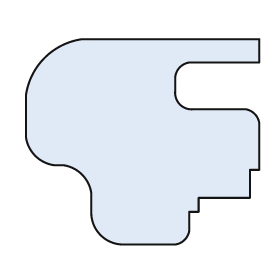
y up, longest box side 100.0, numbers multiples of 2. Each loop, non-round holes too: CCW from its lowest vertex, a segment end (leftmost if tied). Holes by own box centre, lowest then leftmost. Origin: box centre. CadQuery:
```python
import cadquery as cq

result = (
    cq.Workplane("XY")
    .moveTo(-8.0, -44.0)
    .lineTo(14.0, -44.0)
    .threePointArc((18.0, -42.0), (20.0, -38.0))
    .lineTo(20.0, -30.0)
    .lineTo(24.0, -30.0)
    .lineTo(24.0, -24.0)
    .lineTo(46.0, -24.0)
    .lineTo(46.0, -12.0)
    .lineTo(50.0, -12.0)
    .lineTo(50.0, 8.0)
    .threePointArc((48.0, 12.0), (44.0, 14.0))
    .lineTo(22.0, 14.0)
    .threePointArc((16.0, 16.0), (14.0, 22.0))
    .lineTo(14.0, 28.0)
    .threePointArc((16.0, 32.0), (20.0, 34.0))
    .lineTo(50.0, 34.0)
    .lineTo(50.0, 44.0)
    .lineTo(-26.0, 44.0)
    .threePointArc((-42.0, 36.0), (-50.0, 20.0))
    .lineTo(-50.0, 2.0)
    .threePointArc((-46.0, -6.0), (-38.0, -10.0))
    .lineTo(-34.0, -10.0)
    .threePointArc((-26.0, -14.0), (-22.0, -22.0))
    .lineTo(-22.0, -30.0)
    .threePointArc((-18.0, -40.0), (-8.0, -44.0))
    .close()
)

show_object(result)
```